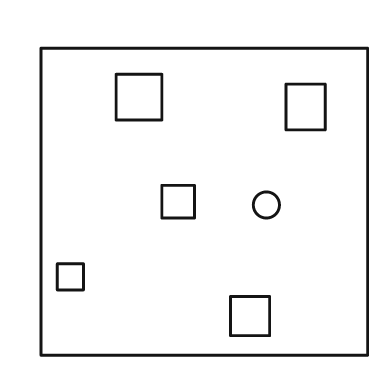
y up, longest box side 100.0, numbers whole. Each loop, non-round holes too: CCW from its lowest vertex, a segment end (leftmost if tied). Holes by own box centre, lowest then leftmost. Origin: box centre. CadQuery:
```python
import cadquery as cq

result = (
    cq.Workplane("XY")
    .moveTo(-50.0, -47.0)
    .lineTo(50.0, -47.0)
    .lineTo(50.0, 47.0)
    .lineTo(-50.0, 47.0)
    .close()
    .moveTo(8.0, -41.0)
    .lineTo(20.0, -41.0)
    .lineTo(20.0, -29.0)
    .lineTo(8.0, -29.0)
    .close()
    .moveTo(-45.0, -27.0)
    .lineTo(-37.0, -27.0)
    .lineTo(-37.0, -19.0)
    .lineTo(-45.0, -19.0)
    .close()
    .moveTo(19.0, -1.0)
    .circle(4.0)
    .moveTo(-13.0, -5.0)
    .lineTo(-3.0, -5.0)
    .lineTo(-3.0, 5.0)
    .lineTo(-13.0, 5.0)
    .close()
    .moveTo(25.0, 22.0)
    .lineTo(37.0, 22.0)
    .lineTo(37.0, 36.0)
    .lineTo(25.0, 36.0)
    .close()
    .moveTo(-27.0, 25.0)
    .lineTo(-13.0, 25.0)
    .lineTo(-13.0, 39.0)
    .lineTo(-27.0, 39.0)
    .close()
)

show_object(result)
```